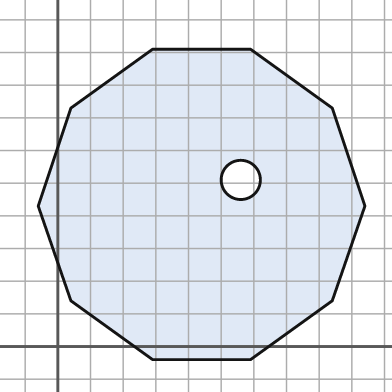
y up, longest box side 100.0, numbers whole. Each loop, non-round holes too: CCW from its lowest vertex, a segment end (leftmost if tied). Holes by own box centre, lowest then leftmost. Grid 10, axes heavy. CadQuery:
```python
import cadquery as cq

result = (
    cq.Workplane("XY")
    .moveTo(29.0, -4.0)
    .lineTo(59.0, -4.0)
    .lineTo(84.0, 14.0)
    .lineTo(94.0, 43.0)
    .lineTo(84.0, 73.0)
    .lineTo(59.0, 91.0)
    .lineTo(29.0, 91.0)
    .lineTo(4.0, 73.0)
    .lineTo(-6.0, 43.0)
    .lineTo(4.0, 14.0)
    .close()
    .moveTo(56.0, 51.0)
    .circle(6.0)
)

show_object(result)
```